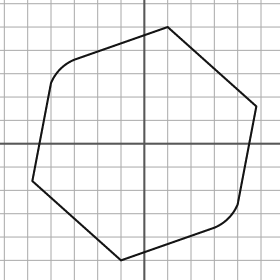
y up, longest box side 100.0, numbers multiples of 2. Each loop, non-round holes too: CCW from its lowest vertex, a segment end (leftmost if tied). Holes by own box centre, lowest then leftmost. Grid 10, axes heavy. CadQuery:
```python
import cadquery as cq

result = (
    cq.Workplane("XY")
    .moveTo(-10.0, -50.0)
    .lineTo(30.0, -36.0)
    .threePointArc((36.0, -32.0), (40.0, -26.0))
    .lineTo(48.0, 16.0)
    .lineTo(10.0, 50.0)
    .lineTo(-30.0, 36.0)
    .threePointArc((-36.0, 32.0), (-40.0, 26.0))
    .lineTo(-48.0, -16.0)
    .close()
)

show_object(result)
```